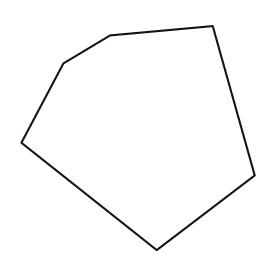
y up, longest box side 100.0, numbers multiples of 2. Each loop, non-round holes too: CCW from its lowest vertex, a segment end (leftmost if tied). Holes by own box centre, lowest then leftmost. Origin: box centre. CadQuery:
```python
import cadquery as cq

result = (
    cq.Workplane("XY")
    .moveTo(8.0, -48.0)
    .lineTo(50.0, -16.0)
    .lineTo(32.0, 48.0)
    .lineTo(-12.0, 44.0)
    .lineTo(-32.0, 32.0)
    .lineTo(-50.0, -2.0)
    .close()
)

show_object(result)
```